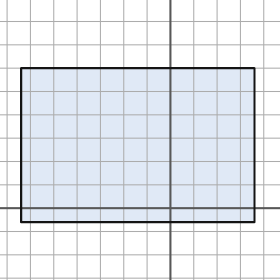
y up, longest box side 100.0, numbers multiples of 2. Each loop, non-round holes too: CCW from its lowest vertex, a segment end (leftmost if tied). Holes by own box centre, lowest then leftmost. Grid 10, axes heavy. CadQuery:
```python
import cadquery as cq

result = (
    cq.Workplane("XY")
    .moveTo(-64.0, -6.0)
    .lineTo(36.0, -6.0)
    .lineTo(36.0, 60.0)
    .lineTo(-64.0, 60.0)
    .close()
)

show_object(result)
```